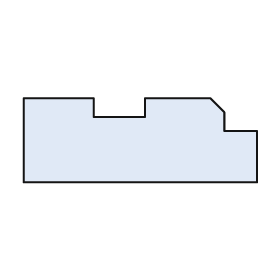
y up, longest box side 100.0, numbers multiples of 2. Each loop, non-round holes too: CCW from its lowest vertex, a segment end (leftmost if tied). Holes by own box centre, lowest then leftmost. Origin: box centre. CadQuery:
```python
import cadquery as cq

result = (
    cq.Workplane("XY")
    .moveTo(-50.0, -18.0)
    .lineTo(50.0, -18.0)
    .lineTo(50.0, 4.0)
    .lineTo(36.0, 4.0)
    .lineTo(36.0, 12.0)
    .lineTo(30.0, 18.0)
    .lineTo(2.0, 18.0)
    .lineTo(2.0, 10.0)
    .lineTo(-20.0, 10.0)
    .lineTo(-20.0, 18.0)
    .lineTo(-50.0, 18.0)
    .close()
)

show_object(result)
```